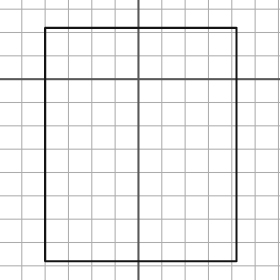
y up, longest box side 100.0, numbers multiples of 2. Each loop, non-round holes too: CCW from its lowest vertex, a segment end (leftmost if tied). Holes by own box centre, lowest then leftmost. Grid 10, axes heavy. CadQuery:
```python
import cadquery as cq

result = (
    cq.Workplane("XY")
    .moveTo(-40.0, -78.0)
    .lineTo(42.0, -78.0)
    .lineTo(42.0, 22.0)
    .lineTo(-40.0, 22.0)
    .close()
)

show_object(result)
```